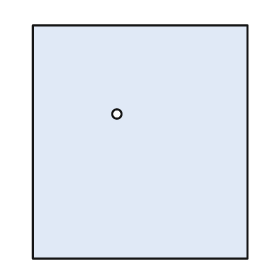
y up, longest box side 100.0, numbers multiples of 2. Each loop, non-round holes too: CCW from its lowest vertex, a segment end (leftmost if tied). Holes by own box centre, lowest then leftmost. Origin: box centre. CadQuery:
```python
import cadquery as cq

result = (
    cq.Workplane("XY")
    .moveTo(-46.0, -50.0)
    .lineTo(46.0, -50.0)
    .lineTo(46.0, 50.0)
    .lineTo(-46.0, 50.0)
    .close()
    .moveTo(-10.0, 12.0)
    .circle(2.0)
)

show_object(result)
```